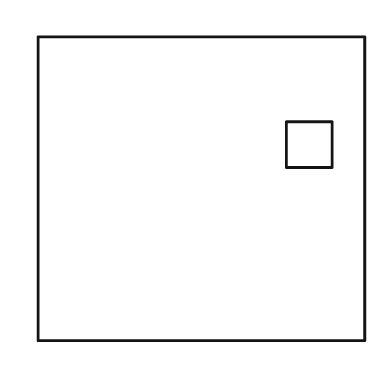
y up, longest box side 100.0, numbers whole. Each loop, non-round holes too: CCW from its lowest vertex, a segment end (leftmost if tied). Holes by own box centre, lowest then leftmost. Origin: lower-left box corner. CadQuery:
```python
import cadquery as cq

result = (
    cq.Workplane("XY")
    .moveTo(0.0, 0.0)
    .lineTo(100.0, 0.0)
    .lineTo(100.0, 93.0)
    .lineTo(0.0, 93.0)
    .close()
    .moveTo(76.0, 53.0)
    .lineTo(90.0, 53.0)
    .lineTo(90.0, 67.0)
    .lineTo(76.0, 67.0)
    .close()
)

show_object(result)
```